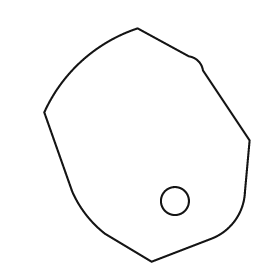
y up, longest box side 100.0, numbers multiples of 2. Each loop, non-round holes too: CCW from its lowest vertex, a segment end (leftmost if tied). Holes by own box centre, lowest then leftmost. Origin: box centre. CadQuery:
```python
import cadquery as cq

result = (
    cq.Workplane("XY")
    .moveTo(2.0, -50.0)
    .lineTo(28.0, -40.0)
    .threePointArc((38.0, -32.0), (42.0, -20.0))
    .lineTo(44.0, 2.0)
    .lineTo(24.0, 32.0)
    .threePointArc((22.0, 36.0), (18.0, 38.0))
    .lineTo(-4.0, 50.0)
    .threePointArc((-28.0, 36.0), (-44.0, 14.0))
    .lineTo(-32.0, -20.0)
    .threePointArc((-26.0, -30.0), (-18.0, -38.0))
    .close()
    .moveTo(12.0, -24.0)
    .circle(6.0)
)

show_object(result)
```